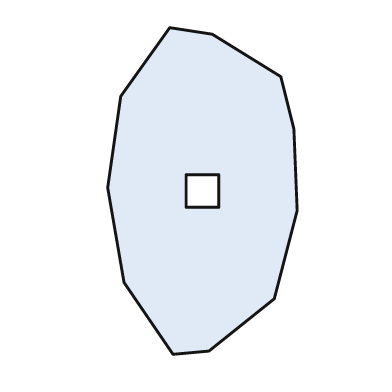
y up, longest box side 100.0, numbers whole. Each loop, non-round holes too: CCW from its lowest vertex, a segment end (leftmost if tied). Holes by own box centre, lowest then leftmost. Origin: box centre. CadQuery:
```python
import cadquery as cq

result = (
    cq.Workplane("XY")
    .moveTo(-9.0, -50.0)
    .lineTo(2.0, -49.0)
    .lineTo(22.0, -33.0)
    .lineTo(29.0, -6.0)
    .lineTo(28.0, 19.0)
    .lineTo(24.0, 35.0)
    .lineTo(3.0, 48.0)
    .lineTo(-10.0, 50.0)
    .lineTo(-25.0, 29.0)
    .lineTo(-29.0, 1.0)
    .lineTo(-24.0, -28.0)
    .close()
    .moveTo(-5.0, -5.0)
    .lineTo(5.0, -5.0)
    .lineTo(5.0, 5.0)
    .lineTo(-5.0, 5.0)
    .close()
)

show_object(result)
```